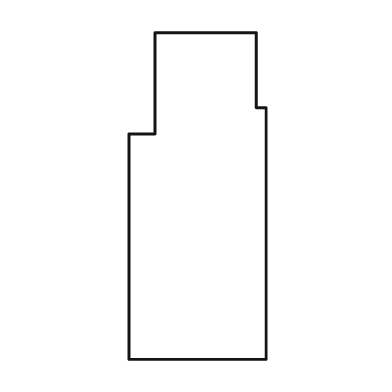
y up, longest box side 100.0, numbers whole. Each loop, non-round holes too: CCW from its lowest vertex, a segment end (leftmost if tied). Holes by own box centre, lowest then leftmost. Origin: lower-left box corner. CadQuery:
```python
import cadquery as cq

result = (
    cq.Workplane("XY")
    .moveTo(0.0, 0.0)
    .lineTo(42.0, 0.0)
    .lineTo(42.0, 77.0)
    .lineTo(39.0, 77.0)
    .lineTo(39.0, 100.0)
    .lineTo(8.0, 100.0)
    .lineTo(8.0, 69.0)
    .lineTo(0.0, 69.0)
    .close()
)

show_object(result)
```